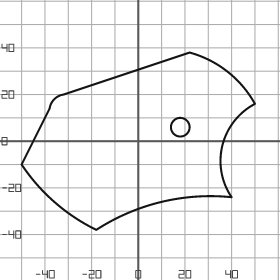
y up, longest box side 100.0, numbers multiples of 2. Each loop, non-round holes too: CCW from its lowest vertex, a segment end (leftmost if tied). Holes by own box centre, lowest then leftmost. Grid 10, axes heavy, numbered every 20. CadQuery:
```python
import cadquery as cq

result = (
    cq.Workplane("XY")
    .moveTo(-18.0, -38.0)
    .threePointArc((10.0, -26.0), (40.0, -24.0))
    .threePointArc((36.0, -2.0), (50.0, 16.0))
    .threePointArc((38.0, 30.0), (22.0, 38.0))
    .lineTo(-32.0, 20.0)
    .threePointArc((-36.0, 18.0), (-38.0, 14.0))
    .lineTo(-50.0, -10.0)
    .threePointArc((-36.0, -26.0), (-18.0, -38.0))
    .close()
    .moveTo(18.0, 6.0)
    .circle(4.0)
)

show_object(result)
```